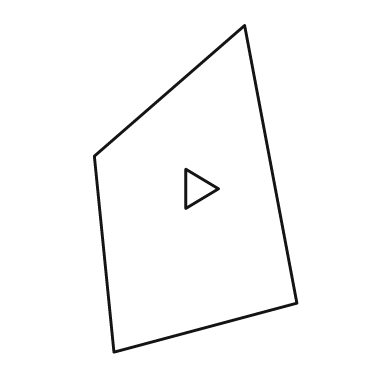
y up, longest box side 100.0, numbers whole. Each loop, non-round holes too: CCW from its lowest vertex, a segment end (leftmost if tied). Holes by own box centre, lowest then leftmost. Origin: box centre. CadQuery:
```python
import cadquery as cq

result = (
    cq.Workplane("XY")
    .moveTo(-25.0, -50.0)
    .lineTo(31.0, -35.0)
    .lineTo(15.0, 50.0)
    .lineTo(-31.0, 10.0)
    .close()
    .moveTo(-3.0, -6.0)
    .lineTo(7.0, 0.0)
    .lineTo(-3.0, 6.0)
    .close()
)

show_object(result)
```